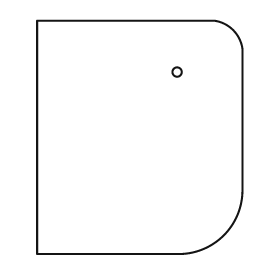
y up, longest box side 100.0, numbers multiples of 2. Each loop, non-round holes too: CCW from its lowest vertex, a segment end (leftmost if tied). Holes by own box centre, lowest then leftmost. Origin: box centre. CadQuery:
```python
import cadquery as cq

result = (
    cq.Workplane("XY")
    .moveTo(-44.0, -50.0)
    .lineTo(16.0, -50.0)
    .threePointArc((36.0, -42.0), (44.0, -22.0))
    .lineTo(44.0, 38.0)
    .threePointArc((40.0, 46.0), (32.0, 50.0))
    .lineTo(-44.0, 50.0)
    .close()
    .moveTo(16.0, 28.0)
    .circle(2.0)
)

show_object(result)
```